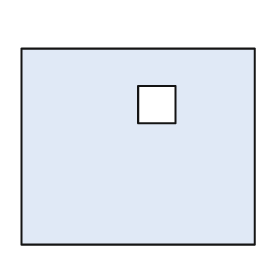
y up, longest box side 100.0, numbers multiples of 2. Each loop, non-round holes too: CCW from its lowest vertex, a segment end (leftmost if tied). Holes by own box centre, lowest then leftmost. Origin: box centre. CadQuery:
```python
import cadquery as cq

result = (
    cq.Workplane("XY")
    .moveTo(-50.0, -42.0)
    .lineTo(50.0, -42.0)
    .lineTo(50.0, 42.0)
    .lineTo(-50.0, 42.0)
    .close()
    .moveTo(0.0, 10.0)
    .lineTo(16.0, 10.0)
    .lineTo(16.0, 26.0)
    .lineTo(0.0, 26.0)
    .close()
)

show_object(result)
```